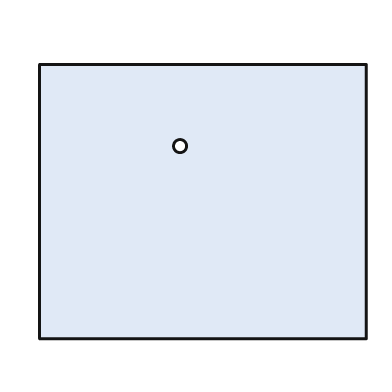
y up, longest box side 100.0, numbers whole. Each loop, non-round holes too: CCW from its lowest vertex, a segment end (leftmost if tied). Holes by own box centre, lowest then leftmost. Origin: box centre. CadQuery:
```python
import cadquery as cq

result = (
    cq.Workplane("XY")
    .moveTo(-50.0, -42.0)
    .lineTo(50.0, -42.0)
    .lineTo(50.0, 42.0)
    .lineTo(-50.0, 42.0)
    .close()
    .moveTo(-7.0, 17.0)
    .circle(2.0)
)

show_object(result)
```